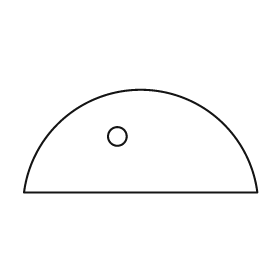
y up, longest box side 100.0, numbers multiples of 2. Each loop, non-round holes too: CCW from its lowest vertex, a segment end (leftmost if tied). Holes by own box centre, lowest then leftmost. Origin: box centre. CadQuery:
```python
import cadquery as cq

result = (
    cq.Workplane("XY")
    .moveTo(-50.0, -22.0)
    .lineTo(50.0, -22.0)
    .threePointArc((0.0, 22.0), (-50.0, -22.0))
    .close()
    .moveTo(-10.0, 2.0)
    .circle(4.0)
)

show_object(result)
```